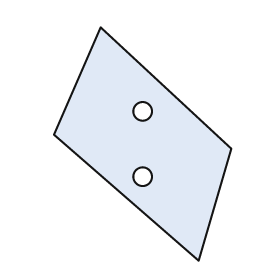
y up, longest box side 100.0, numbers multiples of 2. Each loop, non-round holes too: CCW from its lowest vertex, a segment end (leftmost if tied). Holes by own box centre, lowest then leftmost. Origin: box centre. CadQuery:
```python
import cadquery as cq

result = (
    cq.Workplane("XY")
    .moveTo(24.0, -50.0)
    .lineTo(38.0, -2.0)
    .lineTo(-18.0, 50.0)
    .lineTo(-38.0, 4.0)
    .close()
    .moveTo(0.0, -14.0)
    .circle(4.0)
    .moveTo(0.0, 14.0)
    .circle(4.0)
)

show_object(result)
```